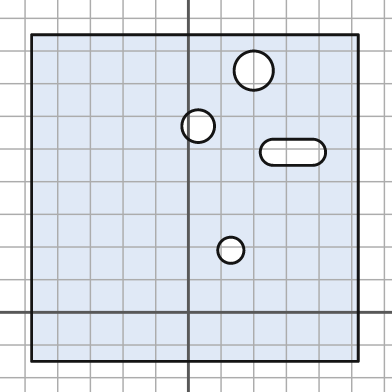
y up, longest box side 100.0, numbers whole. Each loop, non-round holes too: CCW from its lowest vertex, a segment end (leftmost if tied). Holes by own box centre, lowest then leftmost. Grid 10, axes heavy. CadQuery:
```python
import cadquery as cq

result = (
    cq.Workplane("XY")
    .moveTo(-48.0, -15.0)
    .lineTo(52.0, -15.0)
    .lineTo(52.0, 85.0)
    .lineTo(-48.0, 85.0)
    .close()
    .moveTo(13.0, 19.0)
    .circle(4.0)
    .moveTo(26.0, 45.0)
    .lineTo(38.0, 45.0)
    .threePointArc((42.0, 49.0), (38.0, 53.0))
    .lineTo(26.0, 53.0)
    .threePointArc((22.0, 49.0), (26.0, 45.0))
    .close()
    .moveTo(3.0, 57.0)
    .circle(5.0)
    .moveTo(20.0, 74.0)
    .circle(6.0)
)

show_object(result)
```